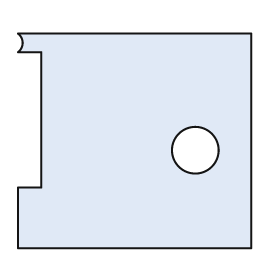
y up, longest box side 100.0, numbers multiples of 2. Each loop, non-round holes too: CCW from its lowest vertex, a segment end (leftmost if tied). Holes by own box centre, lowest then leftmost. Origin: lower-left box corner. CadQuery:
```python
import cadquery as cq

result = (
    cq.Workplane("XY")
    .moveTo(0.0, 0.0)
    .lineTo(100.0, 0.0)
    .lineTo(100.0, 92.0)
    .lineTo(0.0, 92.0)
    .threePointArc((2.0, 88.0), (0.0, 84.0))
    .lineTo(10.0, 84.0)
    .lineTo(10.0, 26.0)
    .lineTo(0.0, 26.0)
    .close()
    .moveTo(76.0, 42.0)
    .circle(10.0)
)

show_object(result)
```